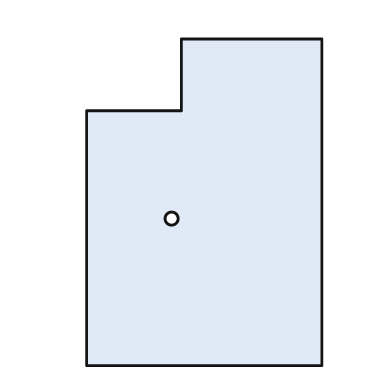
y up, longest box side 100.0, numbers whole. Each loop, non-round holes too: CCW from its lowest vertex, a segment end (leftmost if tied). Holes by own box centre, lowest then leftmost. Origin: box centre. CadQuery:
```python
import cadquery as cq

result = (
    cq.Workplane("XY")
    .moveTo(-36.0, -50.0)
    .lineTo(36.0, -50.0)
    .lineTo(36.0, 50.0)
    .lineTo(-7.0, 50.0)
    .lineTo(-7.0, 28.0)
    .lineTo(-36.0, 28.0)
    .close()
    .moveTo(-10.0, -5.0)
    .circle(2.0)
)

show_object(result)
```